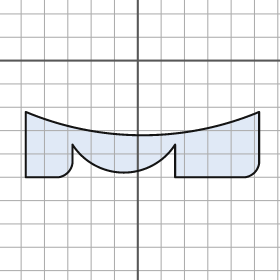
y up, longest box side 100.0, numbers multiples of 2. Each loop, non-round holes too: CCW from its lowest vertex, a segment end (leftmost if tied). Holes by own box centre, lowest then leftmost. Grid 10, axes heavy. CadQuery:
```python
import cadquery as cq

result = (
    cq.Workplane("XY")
    .moveTo(-48.0, -50.0)
    .lineTo(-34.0, -50.0)
    .threePointArc((-30.0, -48.0), (-28.0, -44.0))
    .lineTo(-28.0, -36.0)
    .threePointArc((-6.0, -48.0), (16.0, -36.0))
    .lineTo(16.0, -50.0)
    .lineTo(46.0, -50.0)
    .threePointArc((50.0, -48.0), (52.0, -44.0))
    .lineTo(52.0, -22.0)
    .threePointArc((2.0, -32.0), (-48.0, -22.0))
    .close()
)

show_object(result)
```